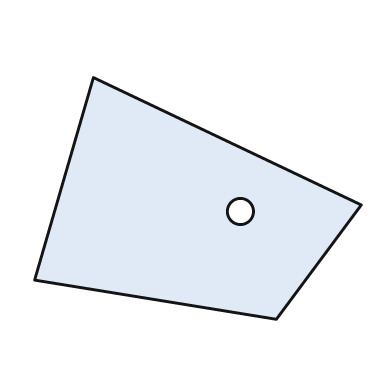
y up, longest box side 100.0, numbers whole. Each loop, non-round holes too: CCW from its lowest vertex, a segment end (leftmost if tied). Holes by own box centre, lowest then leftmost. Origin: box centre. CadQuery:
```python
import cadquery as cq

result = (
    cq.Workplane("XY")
    .moveTo(24.0, -37.0)
    .lineTo(50.0, -2.0)
    .lineTo(-32.0, 37.0)
    .lineTo(-50.0, -25.0)
    .close()
    .moveTo(13.0, -4.0)
    .circle(4.0)
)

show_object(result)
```